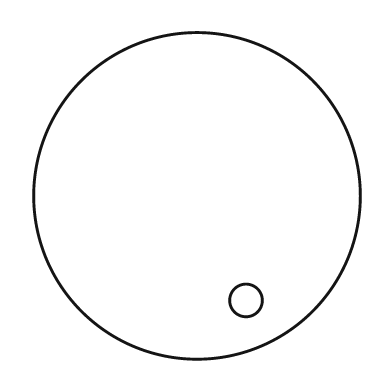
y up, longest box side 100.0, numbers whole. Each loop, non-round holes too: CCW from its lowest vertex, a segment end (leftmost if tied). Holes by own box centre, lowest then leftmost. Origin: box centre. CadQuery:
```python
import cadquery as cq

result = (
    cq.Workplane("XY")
    .moveTo(0.0, 0.0)
    .circle(50.0)
    .moveTo(15.0, -32.0)
    .circle(5.0)
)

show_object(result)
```